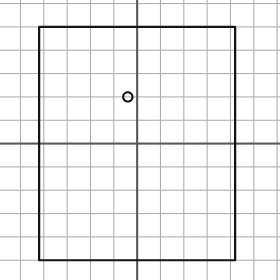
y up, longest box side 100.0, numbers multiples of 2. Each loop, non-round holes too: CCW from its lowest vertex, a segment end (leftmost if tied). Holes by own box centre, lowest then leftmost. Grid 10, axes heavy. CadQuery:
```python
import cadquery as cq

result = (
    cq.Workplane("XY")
    .moveTo(-42.0, -50.0)
    .lineTo(42.0, -50.0)
    .lineTo(42.0, 50.0)
    .lineTo(-42.0, 50.0)
    .close()
    .moveTo(-4.0, 20.0)
    .circle(2.0)
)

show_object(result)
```